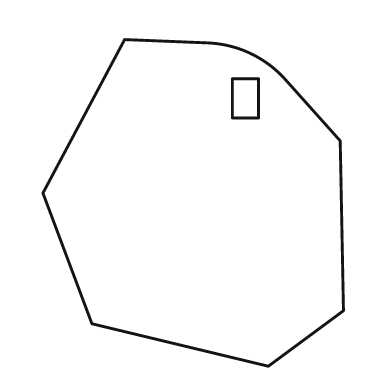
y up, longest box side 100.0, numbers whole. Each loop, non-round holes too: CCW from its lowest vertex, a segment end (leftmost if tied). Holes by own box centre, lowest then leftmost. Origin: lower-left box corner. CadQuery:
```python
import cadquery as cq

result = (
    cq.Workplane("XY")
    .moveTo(69.0, 0.0)
    .lineTo(92.0, 17.0)
    .lineTo(91.0, 69.0)
    .lineTo(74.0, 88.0)
    .threePointArc((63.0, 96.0), (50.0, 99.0))
    .lineTo(25.0, 100.0)
    .lineTo(0.0, 53.0)
    .lineTo(15.0, 13.0)
    .close()
    .moveTo(58.0, 76.0)
    .lineTo(66.0, 76.0)
    .lineTo(66.0, 88.0)
    .lineTo(58.0, 88.0)
    .close()
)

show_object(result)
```